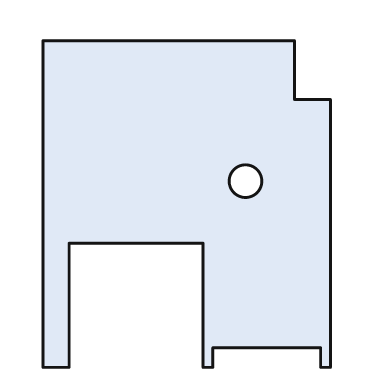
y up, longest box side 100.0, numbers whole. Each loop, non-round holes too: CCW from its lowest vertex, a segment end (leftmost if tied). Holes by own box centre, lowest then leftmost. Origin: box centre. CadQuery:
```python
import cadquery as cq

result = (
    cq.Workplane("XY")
    .moveTo(-44.0, -50.0)
    .lineTo(-36.0, -50.0)
    .lineTo(-36.0, -12.0)
    .lineTo(5.0, -12.0)
    .lineTo(5.0, -50.0)
    .lineTo(8.0, -50.0)
    .lineTo(8.0, -44.0)
    .lineTo(41.0, -44.0)
    .lineTo(41.0, -50.0)
    .lineTo(44.0, -50.0)
    .lineTo(44.0, 32.0)
    .lineTo(33.0, 32.0)
    .lineTo(33.0, 50.0)
    .lineTo(-44.0, 50.0)
    .close()
    .moveTo(18.0, 7.0)
    .circle(5.0)
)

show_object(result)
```